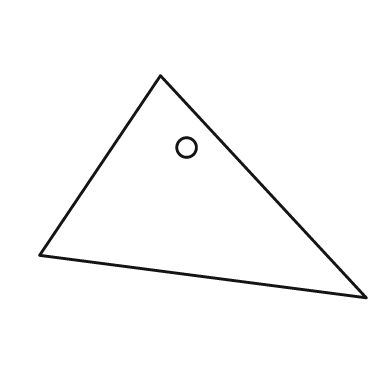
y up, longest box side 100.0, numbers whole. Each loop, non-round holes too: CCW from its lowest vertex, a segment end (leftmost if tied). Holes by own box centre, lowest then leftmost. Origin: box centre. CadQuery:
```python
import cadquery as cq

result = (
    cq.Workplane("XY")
    .moveTo(50.0, -34.0)
    .lineTo(-13.0, 34.0)
    .lineTo(-50.0, -21.0)
    .close()
    .moveTo(-5.0, 12.0)
    .circle(3.0)
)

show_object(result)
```